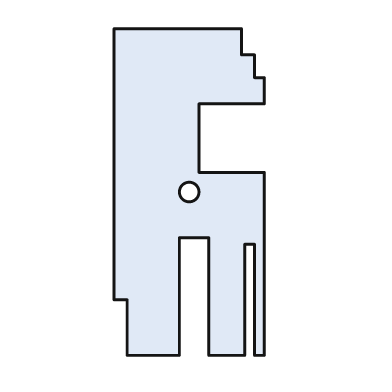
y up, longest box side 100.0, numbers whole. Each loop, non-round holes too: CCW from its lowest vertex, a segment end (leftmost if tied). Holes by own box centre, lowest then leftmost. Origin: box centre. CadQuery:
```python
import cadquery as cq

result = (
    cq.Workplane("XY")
    .moveTo(-19.0, -50.0)
    .lineTo(-3.0, -50.0)
    .lineTo(-3.0, -14.0)
    .lineTo(6.0, -14.0)
    .lineTo(6.0, -50.0)
    .lineTo(17.0, -50.0)
    .lineTo(17.0, -16.0)
    .lineTo(20.0, -16.0)
    .lineTo(20.0, -50.0)
    .lineTo(23.0, -50.0)
    .lineTo(23.0, 6.0)
    .lineTo(3.0, 6.0)
    .lineTo(3.0, 27.0)
    .lineTo(23.0, 27.0)
    .lineTo(23.0, 35.0)
    .lineTo(20.0, 35.0)
    .lineTo(20.0, 42.0)
    .lineTo(16.0, 42.0)
    .lineTo(16.0, 50.0)
    .lineTo(-23.0, 50.0)
    .lineTo(-23.0, -33.0)
    .lineTo(-19.0, -33.0)
    .close()
    .moveTo(0.0, 0.0)
    .circle(3.0)
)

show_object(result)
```